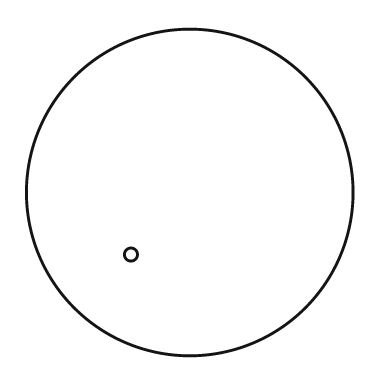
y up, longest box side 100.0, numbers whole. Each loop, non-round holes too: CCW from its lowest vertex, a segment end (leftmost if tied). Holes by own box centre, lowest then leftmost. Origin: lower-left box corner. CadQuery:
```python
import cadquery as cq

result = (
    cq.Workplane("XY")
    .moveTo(50.0, 50.0)
    .circle(50.0)
    .moveTo(32.0, 31.0)
    .circle(2.0)
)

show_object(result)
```